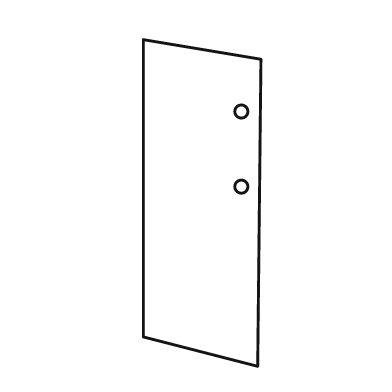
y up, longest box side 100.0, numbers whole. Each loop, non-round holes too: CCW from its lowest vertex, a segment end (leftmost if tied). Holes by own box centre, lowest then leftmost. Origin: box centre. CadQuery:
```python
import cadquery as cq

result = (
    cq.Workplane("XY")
    .moveTo(17.0, -50.0)
    .lineTo(18.0, 44.0)
    .lineTo(-18.0, 50.0)
    .lineTo(-18.0, -41.0)
    .close()
    .moveTo(12.0, 5.0)
    .circle(2.0)
    .moveTo(12.0, 28.0)
    .circle(2.0)
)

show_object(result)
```